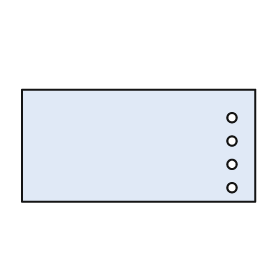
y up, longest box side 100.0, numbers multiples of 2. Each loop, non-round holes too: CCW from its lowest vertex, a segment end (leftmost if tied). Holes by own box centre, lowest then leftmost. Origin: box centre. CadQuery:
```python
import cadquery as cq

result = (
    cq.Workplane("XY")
    .moveTo(-50.0, -24.0)
    .lineTo(50.0, -24.0)
    .lineTo(50.0, 24.0)
    .lineTo(-50.0, 24.0)
    .close()
    .moveTo(40.0, -18.0)
    .circle(2.0)
    .moveTo(40.0, -8.0)
    .circle(2.0)
    .moveTo(40.0, 2.0)
    .circle(2.0)
    .moveTo(40.0, 12.0)
    .circle(2.0)
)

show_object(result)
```